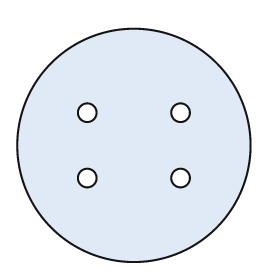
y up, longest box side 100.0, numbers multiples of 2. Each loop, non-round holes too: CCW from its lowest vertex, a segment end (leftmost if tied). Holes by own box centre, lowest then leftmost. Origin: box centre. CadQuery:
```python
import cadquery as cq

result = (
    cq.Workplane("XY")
    .moveTo(0.0, 0.0)
    .circle(50.0)
    .moveTo(-20.0, -14.0)
    .circle(4.0)
    .moveTo(20.0, -14.0)
    .circle(4.0)
    .moveTo(-20.0, 14.0)
    .circle(4.0)
    .moveTo(20.0, 14.0)
    .circle(4.0)
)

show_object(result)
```